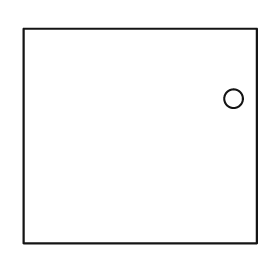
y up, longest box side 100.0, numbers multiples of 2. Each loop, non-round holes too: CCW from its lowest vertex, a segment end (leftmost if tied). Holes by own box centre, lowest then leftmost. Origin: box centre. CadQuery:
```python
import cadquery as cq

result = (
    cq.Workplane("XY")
    .moveTo(-50.0, -46.0)
    .lineTo(50.0, -46.0)
    .lineTo(50.0, 46.0)
    .lineTo(-50.0, 46.0)
    .close()
    .moveTo(40.0, 16.0)
    .circle(4.0)
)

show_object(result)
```